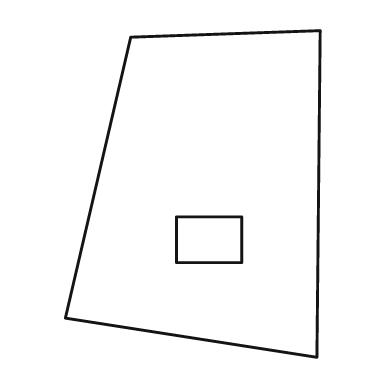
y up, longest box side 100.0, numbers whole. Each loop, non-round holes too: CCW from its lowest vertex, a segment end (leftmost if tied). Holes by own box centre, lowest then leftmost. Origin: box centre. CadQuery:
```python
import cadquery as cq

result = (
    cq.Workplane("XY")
    .moveTo(38.0, -50.0)
    .lineTo(39.0, 50.0)
    .lineTo(-19.0, 48.0)
    .lineTo(-39.0, -38.0)
    .close()
    .moveTo(-5.0, -21.0)
    .lineTo(15.0, -21.0)
    .lineTo(15.0, -7.0)
    .lineTo(-5.0, -7.0)
    .close()
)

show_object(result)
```